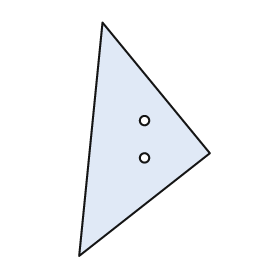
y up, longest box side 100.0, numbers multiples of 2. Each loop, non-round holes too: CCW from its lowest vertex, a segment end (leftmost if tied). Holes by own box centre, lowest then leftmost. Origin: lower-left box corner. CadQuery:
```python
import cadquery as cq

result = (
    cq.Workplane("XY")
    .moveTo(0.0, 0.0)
    .lineTo(56.0, 44.0)
    .lineTo(10.0, 100.0)
    .close()
    .moveTo(28.0, 42.0)
    .circle(2.0)
    .moveTo(28.0, 58.0)
    .circle(2.0)
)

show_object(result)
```